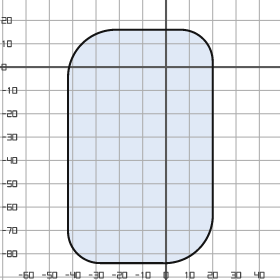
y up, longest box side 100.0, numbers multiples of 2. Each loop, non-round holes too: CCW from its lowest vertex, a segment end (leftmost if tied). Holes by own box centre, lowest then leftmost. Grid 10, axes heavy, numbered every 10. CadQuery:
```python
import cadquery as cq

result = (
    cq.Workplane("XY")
    .moveTo(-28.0, -84.0)
    .lineTo(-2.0, -84.0)
    .threePointArc((14.0, -78.0), (20.0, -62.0))
    .lineTo(20.0, 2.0)
    .threePointArc((16.0, 12.0), (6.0, 16.0))
    .lineTo(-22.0, 16.0)
    .threePointArc((-36.0, 10.0), (-42.0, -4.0))
    .lineTo(-42.0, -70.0)
    .threePointArc((-38.0, -80.0), (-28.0, -84.0))
    .close()
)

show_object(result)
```